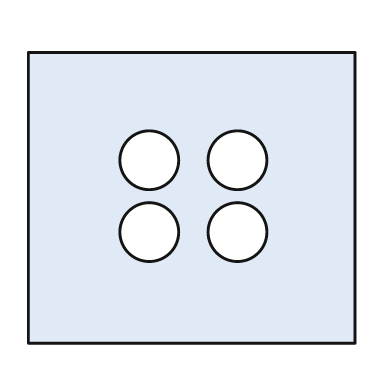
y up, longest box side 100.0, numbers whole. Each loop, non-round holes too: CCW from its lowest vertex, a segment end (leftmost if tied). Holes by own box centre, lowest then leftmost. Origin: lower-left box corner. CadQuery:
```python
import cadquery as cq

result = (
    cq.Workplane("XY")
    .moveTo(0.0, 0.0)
    .lineTo(100.0, 0.0)
    .lineTo(100.0, 89.0)
    .lineTo(0.0, 89.0)
    .close()
    .moveTo(37.0, 34.0)
    .circle(9.0)
    .moveTo(64.0, 34.0)
    .circle(9.0)
    .moveTo(37.0, 56.0)
    .circle(9.0)
    .moveTo(64.0, 56.0)
    .circle(9.0)
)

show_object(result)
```